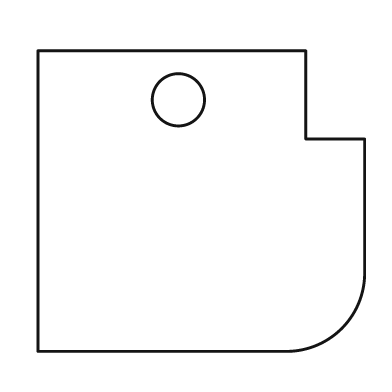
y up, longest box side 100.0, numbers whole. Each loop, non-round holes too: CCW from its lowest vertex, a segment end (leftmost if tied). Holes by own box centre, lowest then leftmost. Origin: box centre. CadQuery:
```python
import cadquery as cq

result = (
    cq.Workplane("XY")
    .moveTo(-50.0, -46.0)
    .lineTo(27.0, -46.0)
    .threePointArc((43.0, -39.0), (50.0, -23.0))
    .lineTo(50.0, 19.0)
    .lineTo(32.0, 19.0)
    .lineTo(32.0, 46.0)
    .lineTo(-50.0, 46.0)
    .close()
    .moveTo(-7.0, 31.0)
    .circle(8.0)
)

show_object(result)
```